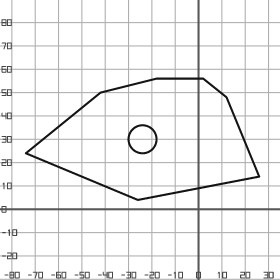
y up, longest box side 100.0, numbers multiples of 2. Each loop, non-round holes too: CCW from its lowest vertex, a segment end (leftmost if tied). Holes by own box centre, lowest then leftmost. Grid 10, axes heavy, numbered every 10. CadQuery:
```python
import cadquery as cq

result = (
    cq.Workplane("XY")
    .moveTo(-26.0, 4.0)
    .lineTo(26.0, 14.0)
    .lineTo(12.0, 48.0)
    .lineTo(2.0, 56.0)
    .lineTo(-18.0, 56.0)
    .lineTo(-42.0, 50.0)
    .lineTo(-74.0, 24.0)
    .close()
    .moveTo(-24.0, 30.0)
    .circle(6.0)
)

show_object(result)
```